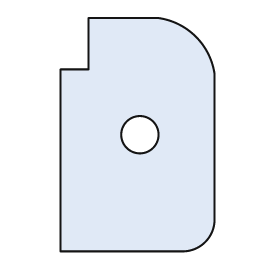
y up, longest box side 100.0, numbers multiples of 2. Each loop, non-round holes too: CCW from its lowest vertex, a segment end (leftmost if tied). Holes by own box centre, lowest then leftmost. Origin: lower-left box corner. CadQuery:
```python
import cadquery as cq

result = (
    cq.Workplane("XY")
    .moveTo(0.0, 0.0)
    .lineTo(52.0, 0.0)
    .threePointArc((62.0, 4.0), (66.0, 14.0))
    .lineTo(66.0, 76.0)
    .threePointArc((58.0, 92.0), (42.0, 100.0))
    .lineTo(12.0, 100.0)
    .lineTo(12.0, 78.0)
    .lineTo(0.0, 78.0)
    .close()
    .moveTo(34.0, 50.0)
    .circle(8.0)
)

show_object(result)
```